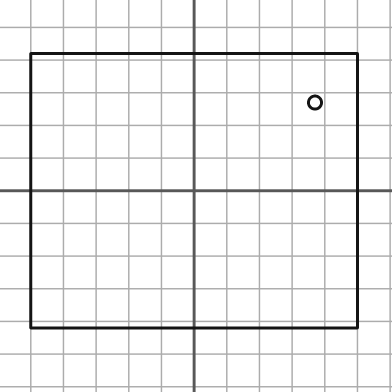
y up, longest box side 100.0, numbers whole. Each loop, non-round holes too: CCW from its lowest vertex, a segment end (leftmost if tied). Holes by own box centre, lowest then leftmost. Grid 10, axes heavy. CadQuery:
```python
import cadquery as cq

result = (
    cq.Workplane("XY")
    .moveTo(-50.0, -42.0)
    .lineTo(50.0, -42.0)
    .lineTo(50.0, 42.0)
    .lineTo(-50.0, 42.0)
    .close()
    .moveTo(37.0, 27.0)
    .circle(2.0)
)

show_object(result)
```